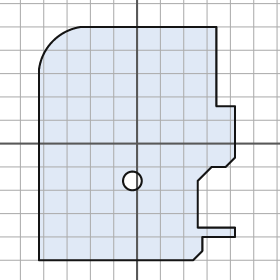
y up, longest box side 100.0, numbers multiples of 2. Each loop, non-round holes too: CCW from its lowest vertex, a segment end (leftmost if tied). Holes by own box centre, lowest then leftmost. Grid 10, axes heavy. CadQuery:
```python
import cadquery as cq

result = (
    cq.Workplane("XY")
    .moveTo(-42.0, -50.0)
    .lineTo(24.0, -50.0)
    .lineTo(28.0, -46.0)
    .lineTo(28.0, -40.0)
    .lineTo(42.0, -40.0)
    .lineTo(42.0, -36.0)
    .lineTo(26.0, -36.0)
    .lineTo(26.0, -16.0)
    .lineTo(32.0, -10.0)
    .lineTo(38.0, -10.0)
    .lineTo(42.0, -6.0)
    .lineTo(42.0, 16.0)
    .lineTo(34.0, 16.0)
    .lineTo(34.0, 50.0)
    .lineTo(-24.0, 50.0)
    .threePointArc((-36.0, 44.0), (-42.0, 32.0))
    .close()
    .moveTo(-2.0, -16.0)
    .circle(4.0)
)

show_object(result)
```